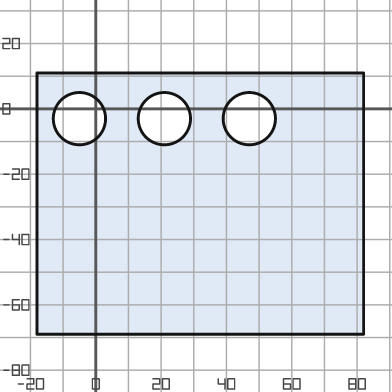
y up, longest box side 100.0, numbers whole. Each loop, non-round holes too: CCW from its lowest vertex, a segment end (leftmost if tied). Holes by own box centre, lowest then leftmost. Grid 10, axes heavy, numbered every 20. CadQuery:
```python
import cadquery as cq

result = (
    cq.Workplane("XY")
    .moveTo(-18.0, -69.0)
    .lineTo(82.0, -69.0)
    .lineTo(82.0, 11.0)
    .lineTo(-18.0, 11.0)
    .close()
    .moveTo(-5.0, -3.0)
    .circle(8.0)
    .moveTo(21.0, -3.0)
    .circle(8.0)
    .moveTo(47.0, -3.0)
    .circle(8.0)
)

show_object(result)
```